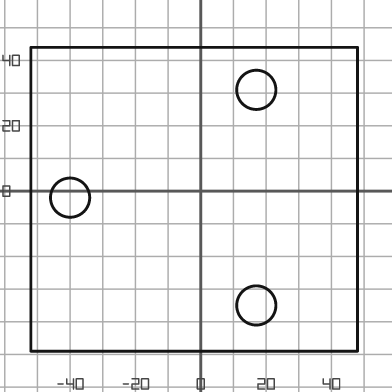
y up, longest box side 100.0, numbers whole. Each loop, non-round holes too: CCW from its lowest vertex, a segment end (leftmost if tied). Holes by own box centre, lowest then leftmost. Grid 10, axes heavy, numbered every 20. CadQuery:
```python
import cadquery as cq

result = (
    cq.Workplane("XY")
    .moveTo(-52.0, -49.0)
    .lineTo(48.0, -49.0)
    .lineTo(48.0, 44.0)
    .lineTo(-52.0, 44.0)
    .close()
    .moveTo(17.0, -35.0)
    .circle(6.0)
    .moveTo(-40.0, -2.0)
    .circle(6.0)
    .moveTo(17.0, 31.0)
    .circle(6.0)
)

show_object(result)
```